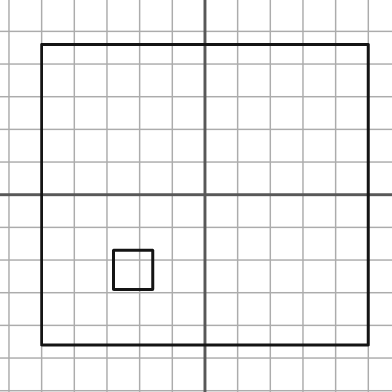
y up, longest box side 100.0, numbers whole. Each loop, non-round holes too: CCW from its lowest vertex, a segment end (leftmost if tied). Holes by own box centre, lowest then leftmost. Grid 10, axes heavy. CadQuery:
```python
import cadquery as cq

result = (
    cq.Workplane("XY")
    .moveTo(-50.0, -46.0)
    .lineTo(50.0, -46.0)
    .lineTo(50.0, 46.0)
    .lineTo(-50.0, 46.0)
    .close()
    .moveTo(-28.0, -29.0)
    .lineTo(-16.0, -29.0)
    .lineTo(-16.0, -17.0)
    .lineTo(-28.0, -17.0)
    .close()
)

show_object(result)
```